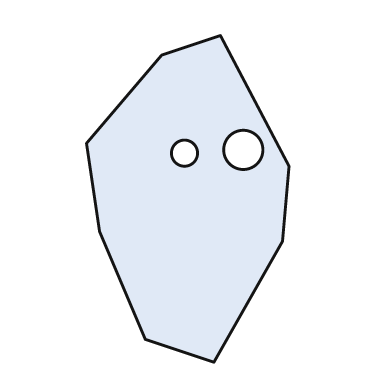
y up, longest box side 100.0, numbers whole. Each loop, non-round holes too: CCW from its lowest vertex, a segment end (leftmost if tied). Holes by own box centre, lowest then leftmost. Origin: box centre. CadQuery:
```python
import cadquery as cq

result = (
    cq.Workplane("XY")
    .moveTo(8.0, -50.0)
    .lineTo(29.0, -13.0)
    .lineTo(31.0, 10.0)
    .lineTo(10.0, 50.0)
    .lineTo(-8.0, 44.0)
    .lineTo(-31.0, 17.0)
    .lineTo(-27.0, -10.0)
    .lineTo(-13.0, -43.0)
    .close()
    .moveTo(-1.0, 14.0)
    .circle(4.0)
    .moveTo(17.0, 15.0)
    .circle(6.0)
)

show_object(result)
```